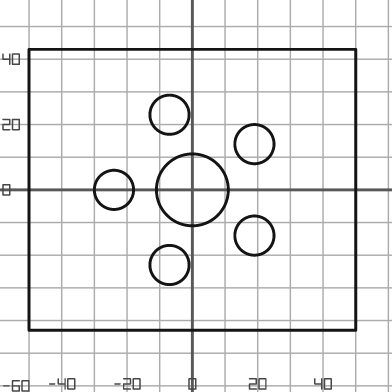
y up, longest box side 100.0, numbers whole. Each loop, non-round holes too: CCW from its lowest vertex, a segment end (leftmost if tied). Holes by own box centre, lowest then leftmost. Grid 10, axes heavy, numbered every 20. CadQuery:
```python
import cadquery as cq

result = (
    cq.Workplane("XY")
    .moveTo(-50.0, -43.0)
    .lineTo(50.0, -43.0)
    .lineTo(50.0, 43.0)
    .lineTo(-50.0, 43.0)
    .close()
    .moveTo(-7.0, -23.0)
    .circle(6.0)
    .moveTo(19.0, -14.0)
    .circle(6.0)
    .moveTo(-24.0, 0.0)
    .circle(6.0)
    .moveTo(0.0, 0.0)
    .circle(11.0)
    .moveTo(19.0, 14.0)
    .circle(6.0)
    .moveTo(-7.0, 23.0)
    .circle(6.0)
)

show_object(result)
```